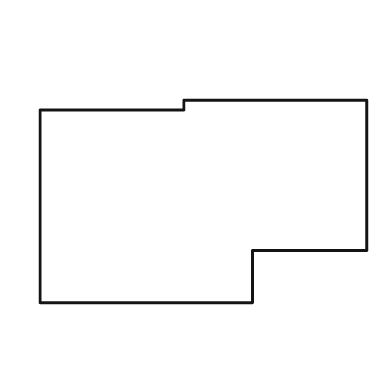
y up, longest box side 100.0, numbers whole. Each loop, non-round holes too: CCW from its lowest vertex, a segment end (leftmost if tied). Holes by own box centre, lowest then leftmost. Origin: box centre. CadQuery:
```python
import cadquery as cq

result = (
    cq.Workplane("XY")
    .moveTo(-50.0, -31.0)
    .lineTo(15.0, -31.0)
    .lineTo(15.0, -15.0)
    .lineTo(50.0, -15.0)
    .lineTo(50.0, 31.0)
    .lineTo(-6.0, 31.0)
    .lineTo(-6.0, 28.0)
    .lineTo(-50.0, 28.0)
    .close()
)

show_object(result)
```